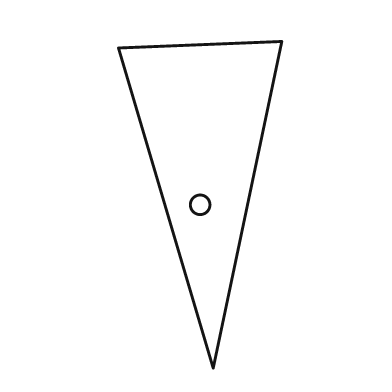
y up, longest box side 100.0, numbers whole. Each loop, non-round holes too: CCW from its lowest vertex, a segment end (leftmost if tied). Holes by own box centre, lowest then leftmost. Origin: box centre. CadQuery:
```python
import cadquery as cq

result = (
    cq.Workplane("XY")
    .moveTo(4.0, -50.0)
    .lineTo(25.0, 50.0)
    .lineTo(-25.0, 48.0)
    .close()
    .moveTo(0.0, 0.0)
    .circle(3.0)
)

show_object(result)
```